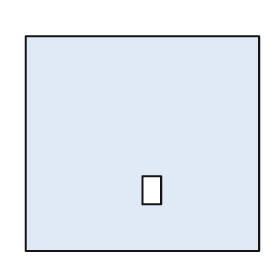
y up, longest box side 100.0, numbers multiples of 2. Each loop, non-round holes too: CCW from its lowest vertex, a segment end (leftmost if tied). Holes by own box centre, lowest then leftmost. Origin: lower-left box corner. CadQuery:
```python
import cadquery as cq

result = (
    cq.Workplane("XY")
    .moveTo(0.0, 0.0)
    .lineTo(100.0, 0.0)
    .lineTo(100.0, 92.0)
    .lineTo(0.0, 92.0)
    .close()
    .moveTo(50.0, 20.0)
    .lineTo(58.0, 20.0)
    .lineTo(58.0, 32.0)
    .lineTo(50.0, 32.0)
    .close()
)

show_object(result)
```